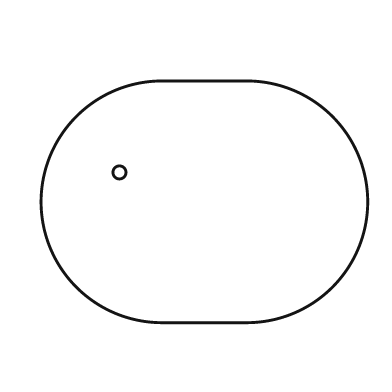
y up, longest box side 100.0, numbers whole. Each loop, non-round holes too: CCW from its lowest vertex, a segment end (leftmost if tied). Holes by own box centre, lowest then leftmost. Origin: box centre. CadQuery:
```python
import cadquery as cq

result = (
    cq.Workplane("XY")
    .moveTo(-13.0, -37.0)
    .lineTo(13.0, -37.0)
    .threePointArc((50.0, 0.0), (13.0, 37.0))
    .lineTo(-13.0, 37.0)
    .threePointArc((-50.0, 0.0), (-13.0, -37.0))
    .close()
    .moveTo(-26.0, 9.0)
    .circle(2.0)
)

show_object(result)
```